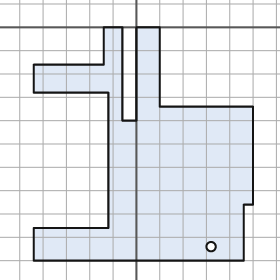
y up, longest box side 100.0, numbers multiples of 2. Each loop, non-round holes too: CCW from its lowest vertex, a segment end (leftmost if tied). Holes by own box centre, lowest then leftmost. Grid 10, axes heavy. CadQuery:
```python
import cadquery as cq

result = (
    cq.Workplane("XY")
    .moveTo(-44.0, -100.0)
    .lineTo(46.0, -100.0)
    .lineTo(46.0, -76.0)
    .lineTo(50.0, -76.0)
    .lineTo(50.0, -34.0)
    .lineTo(10.0, -34.0)
    .lineTo(10.0, 0.0)
    .lineTo(0.0, 0.0)
    .lineTo(0.0, -40.0)
    .lineTo(-6.0, -40.0)
    .lineTo(-6.0, 0.0)
    .lineTo(-14.0, 0.0)
    .lineTo(-14.0, -16.0)
    .lineTo(-44.0, -16.0)
    .lineTo(-44.0, -28.0)
    .lineTo(-12.0, -28.0)
    .lineTo(-12.0, -86.0)
    .lineTo(-44.0, -86.0)
    .close()
    .moveTo(32.0, -94.0)
    .circle(2.0)
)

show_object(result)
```